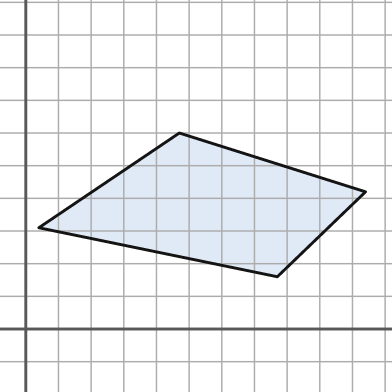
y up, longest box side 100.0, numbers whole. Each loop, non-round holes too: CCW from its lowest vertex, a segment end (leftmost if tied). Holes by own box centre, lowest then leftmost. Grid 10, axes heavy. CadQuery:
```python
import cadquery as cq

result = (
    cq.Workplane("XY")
    .moveTo(77.0, 16.0)
    .lineTo(104.0, 42.0)
    .lineTo(47.0, 60.0)
    .lineTo(4.0, 31.0)
    .close()
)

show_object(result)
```